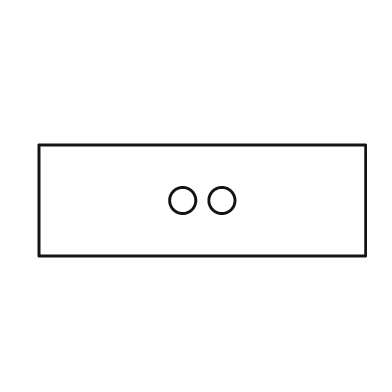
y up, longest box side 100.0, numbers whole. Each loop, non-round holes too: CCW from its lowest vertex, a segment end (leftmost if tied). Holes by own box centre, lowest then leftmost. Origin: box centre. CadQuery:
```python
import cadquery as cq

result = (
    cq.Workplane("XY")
    .moveTo(-50.0, -17.0)
    .lineTo(50.0, -17.0)
    .lineTo(50.0, 17.0)
    .lineTo(-50.0, 17.0)
    .close()
    .moveTo(-6.0, 0.0)
    .circle(4.0)
    .moveTo(6.0, 0.0)
    .circle(4.0)
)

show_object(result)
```